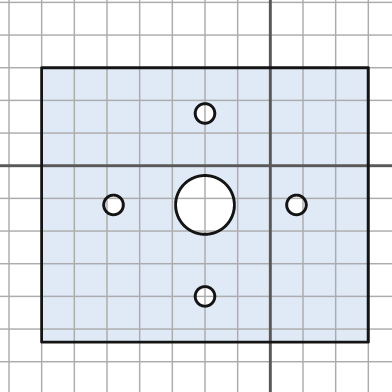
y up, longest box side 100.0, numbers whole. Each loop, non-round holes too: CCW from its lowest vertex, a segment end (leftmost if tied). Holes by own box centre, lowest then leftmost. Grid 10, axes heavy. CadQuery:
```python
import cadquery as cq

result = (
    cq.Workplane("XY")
    .moveTo(-70.0, -54.0)
    .lineTo(30.0, -54.0)
    .lineTo(30.0, 30.0)
    .lineTo(-70.0, 30.0)
    .close()
    .moveTo(-20.0, -40.0)
    .circle(3.0)
    .moveTo(-48.0, -12.0)
    .circle(3.0)
    .moveTo(-20.0, -12.0)
    .circle(9.0)
    .moveTo(8.0, -12.0)
    .circle(3.0)
    .moveTo(-20.0, 16.0)
    .circle(3.0)
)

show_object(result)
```